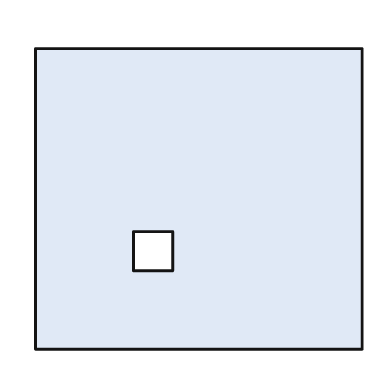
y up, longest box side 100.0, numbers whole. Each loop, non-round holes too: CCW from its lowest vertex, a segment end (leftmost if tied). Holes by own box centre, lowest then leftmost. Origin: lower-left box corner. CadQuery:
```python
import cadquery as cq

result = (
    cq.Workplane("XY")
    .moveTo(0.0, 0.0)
    .lineTo(100.0, 0.0)
    .lineTo(100.0, 92.0)
    .lineTo(0.0, 92.0)
    .close()
    .moveTo(30.0, 24.0)
    .lineTo(42.0, 24.0)
    .lineTo(42.0, 36.0)
    .lineTo(30.0, 36.0)
    .close()
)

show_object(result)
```